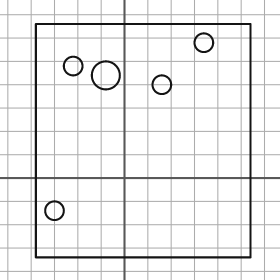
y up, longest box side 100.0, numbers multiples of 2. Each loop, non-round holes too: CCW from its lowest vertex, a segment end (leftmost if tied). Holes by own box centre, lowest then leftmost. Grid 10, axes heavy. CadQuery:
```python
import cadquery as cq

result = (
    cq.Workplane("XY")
    .moveTo(-38.0, -34.0)
    .lineTo(54.0, -34.0)
    .lineTo(54.0, 66.0)
    .lineTo(-38.0, 66.0)
    .close()
    .moveTo(-30.0, -14.0)
    .circle(4.0)
    .moveTo(16.0, 40.0)
    .circle(4.0)
    .moveTo(-8.0, 44.0)
    .circle(6.0)
    .moveTo(-22.0, 48.0)
    .circle(4.0)
    .moveTo(34.0, 58.0)
    .circle(4.0)
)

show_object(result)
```